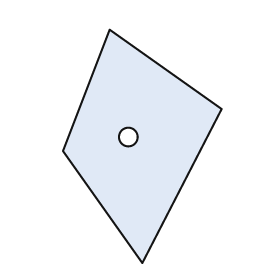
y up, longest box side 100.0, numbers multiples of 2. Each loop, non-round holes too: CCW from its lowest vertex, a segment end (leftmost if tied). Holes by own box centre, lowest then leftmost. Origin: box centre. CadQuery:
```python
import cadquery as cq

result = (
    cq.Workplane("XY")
    .moveTo(0.0, -50.0)
    .lineTo(34.0, 16.0)
    .lineTo(-14.0, 50.0)
    .lineTo(-34.0, -2.0)
    .close()
    .moveTo(-6.0, 4.0)
    .circle(4.0)
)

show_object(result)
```